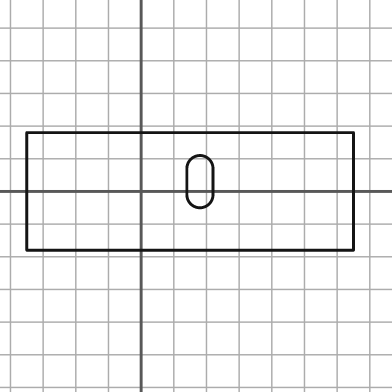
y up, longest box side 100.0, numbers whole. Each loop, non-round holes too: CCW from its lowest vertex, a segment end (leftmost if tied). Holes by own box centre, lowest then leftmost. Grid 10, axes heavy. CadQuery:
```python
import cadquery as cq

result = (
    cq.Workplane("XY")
    .moveTo(-35.0, -18.0)
    .lineTo(65.0, -18.0)
    .lineTo(65.0, 18.0)
    .lineTo(-35.0, 18.0)
    .close()
    .moveTo(14.0, -1.0)
    .threePointArc((18.0, -5.0), (22.0, -1.0))
    .lineTo(22.0, 7.0)
    .threePointArc((18.0, 11.0), (14.0, 7.0))
    .close()
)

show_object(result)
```